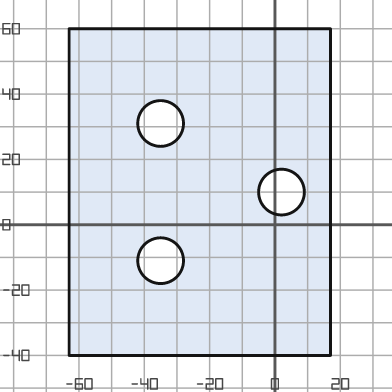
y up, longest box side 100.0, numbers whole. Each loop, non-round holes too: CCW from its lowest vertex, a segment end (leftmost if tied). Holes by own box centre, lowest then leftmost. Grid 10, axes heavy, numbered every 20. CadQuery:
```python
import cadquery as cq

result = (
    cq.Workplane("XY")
    .moveTo(-63.0, -40.0)
    .lineTo(17.0, -40.0)
    .lineTo(17.0, 60.0)
    .lineTo(-63.0, 60.0)
    .close()
    .moveTo(-35.0, -11.0)
    .circle(7.0)
    .moveTo(2.0, 10.0)
    .circle(7.0)
    .moveTo(-35.0, 31.0)
    .circle(7.0)
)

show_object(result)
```